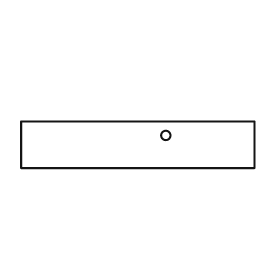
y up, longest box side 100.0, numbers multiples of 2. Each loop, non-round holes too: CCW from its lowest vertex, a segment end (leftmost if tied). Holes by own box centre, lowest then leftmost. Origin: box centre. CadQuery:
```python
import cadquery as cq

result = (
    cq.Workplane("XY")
    .moveTo(-50.0, -10.0)
    .lineTo(50.0, -10.0)
    .lineTo(50.0, 10.0)
    .lineTo(-50.0, 10.0)
    .close()
    .moveTo(12.0, 4.0)
    .circle(2.0)
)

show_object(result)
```